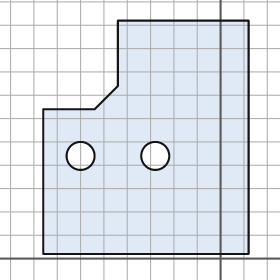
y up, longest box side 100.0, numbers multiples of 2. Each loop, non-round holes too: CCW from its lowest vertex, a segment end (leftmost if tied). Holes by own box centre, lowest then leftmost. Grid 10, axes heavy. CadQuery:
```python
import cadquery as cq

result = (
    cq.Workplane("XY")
    .moveTo(-76.0, 2.0)
    .lineTo(12.0, 2.0)
    .lineTo(12.0, 102.0)
    .lineTo(-44.0, 102.0)
    .lineTo(-44.0, 74.0)
    .lineTo(-54.0, 64.0)
    .lineTo(-76.0, 64.0)
    .close()
    .moveTo(-60.0, 44.0)
    .circle(6.0)
    .moveTo(-28.0, 44.0)
    .circle(6.0)
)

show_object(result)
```